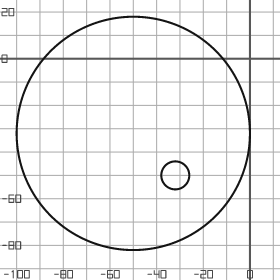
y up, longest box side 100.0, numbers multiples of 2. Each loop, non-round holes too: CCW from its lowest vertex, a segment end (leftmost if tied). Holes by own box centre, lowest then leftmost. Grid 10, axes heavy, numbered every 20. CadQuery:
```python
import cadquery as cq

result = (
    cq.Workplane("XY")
    .moveTo(-50.0, -32.0)
    .circle(50.0)
    .moveTo(-32.0, -50.0)
    .circle(6.0)
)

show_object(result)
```